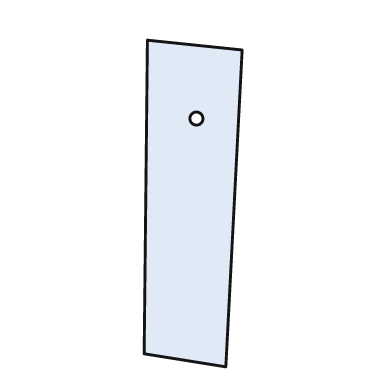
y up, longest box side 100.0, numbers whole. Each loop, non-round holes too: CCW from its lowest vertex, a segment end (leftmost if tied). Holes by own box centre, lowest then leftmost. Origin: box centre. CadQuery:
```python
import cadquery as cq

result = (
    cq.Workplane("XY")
    .moveTo(10.0, -50.0)
    .lineTo(15.0, 47.0)
    .lineTo(-14.0, 50.0)
    .lineTo(-15.0, -46.0)
    .close()
    .moveTo(1.0, 26.0)
    .circle(2.0)
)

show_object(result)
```